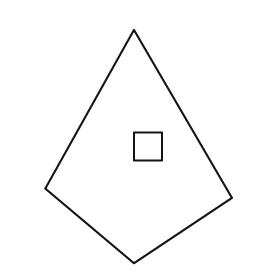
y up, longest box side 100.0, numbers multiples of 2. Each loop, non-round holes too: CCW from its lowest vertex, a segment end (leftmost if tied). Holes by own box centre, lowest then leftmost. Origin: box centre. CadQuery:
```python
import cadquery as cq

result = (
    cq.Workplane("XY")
    .moveTo(-2.0, -50.0)
    .lineTo(40.0, -22.0)
    .lineTo(-2.0, 50.0)
    .lineTo(-40.0, -18.0)
    .close()
    .moveTo(-2.0, -6.0)
    .lineTo(10.0, -6.0)
    .lineTo(10.0, 6.0)
    .lineTo(-2.0, 6.0)
    .close()
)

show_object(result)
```